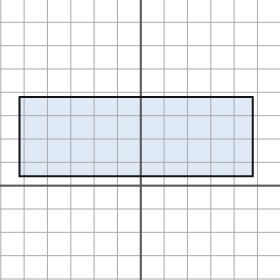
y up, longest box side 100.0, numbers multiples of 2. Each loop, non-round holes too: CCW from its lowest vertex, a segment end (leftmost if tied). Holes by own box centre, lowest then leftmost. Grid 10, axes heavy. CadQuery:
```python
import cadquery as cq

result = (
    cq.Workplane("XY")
    .moveTo(-52.0, 4.0)
    .lineTo(48.0, 4.0)
    .lineTo(48.0, 38.0)
    .lineTo(-52.0, 38.0)
    .close()
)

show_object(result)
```